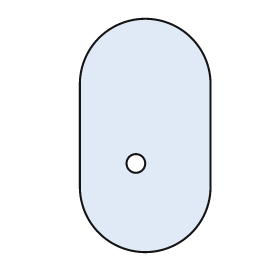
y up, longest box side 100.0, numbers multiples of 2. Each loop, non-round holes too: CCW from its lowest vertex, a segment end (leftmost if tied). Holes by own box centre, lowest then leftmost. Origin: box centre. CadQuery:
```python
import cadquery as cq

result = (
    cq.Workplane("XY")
    .moveTo(-28.0, -22.0)
    .threePointArc((0.0, -50.0), (28.0, -22.0))
    .lineTo(28.0, 22.0)
    .threePointArc((0.0, 50.0), (-28.0, 22.0))
    .close()
    .moveTo(-4.0, -12.0)
    .circle(4.0)
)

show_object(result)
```